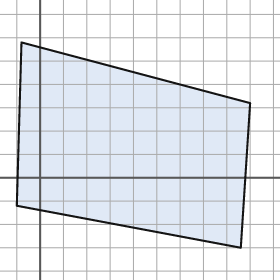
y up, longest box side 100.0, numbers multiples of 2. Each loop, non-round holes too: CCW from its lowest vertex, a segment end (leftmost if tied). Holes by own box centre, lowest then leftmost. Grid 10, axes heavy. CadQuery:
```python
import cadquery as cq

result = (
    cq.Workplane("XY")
    .moveTo(86.0, -30.0)
    .lineTo(90.0, 32.0)
    .lineTo(-8.0, 58.0)
    .lineTo(-10.0, -12.0)
    .close()
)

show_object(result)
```